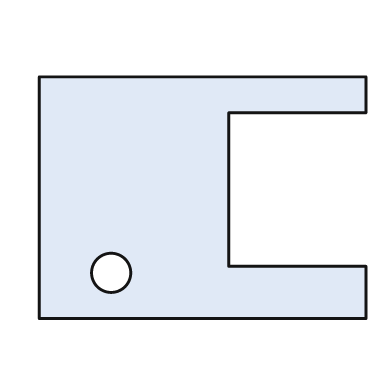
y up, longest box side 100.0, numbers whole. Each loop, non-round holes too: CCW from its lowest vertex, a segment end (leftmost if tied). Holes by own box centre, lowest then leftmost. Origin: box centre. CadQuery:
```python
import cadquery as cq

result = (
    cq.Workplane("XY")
    .moveTo(-50.0, -37.0)
    .lineTo(50.0, -37.0)
    .lineTo(50.0, -21.0)
    .lineTo(8.0, -21.0)
    .lineTo(8.0, 26.0)
    .lineTo(50.0, 26.0)
    .lineTo(50.0, 37.0)
    .lineTo(-50.0, 37.0)
    .close()
    .moveTo(-28.0, -23.0)
    .circle(6.0)
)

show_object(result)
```